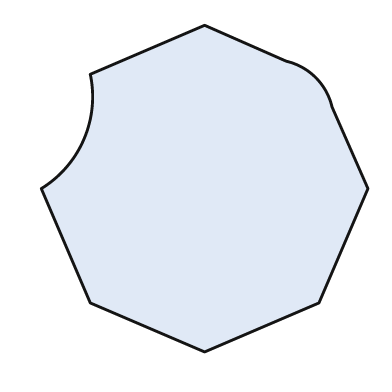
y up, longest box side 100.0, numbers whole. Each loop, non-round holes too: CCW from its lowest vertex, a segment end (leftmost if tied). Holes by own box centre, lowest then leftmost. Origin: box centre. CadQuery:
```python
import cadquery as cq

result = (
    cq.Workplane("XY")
    .moveTo(0.0, -50.0)
    .lineTo(35.0, -35.0)
    .lineTo(50.0, 0.0)
    .lineTo(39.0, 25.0)
    .threePointArc((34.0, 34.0), (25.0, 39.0))
    .lineTo(0.0, 50.0)
    .lineTo(-35.0, 35.0)
    .threePointArc((-37.0, 15.0), (-50.0, 0.0))
    .lineTo(-35.0, -35.0)
    .close()
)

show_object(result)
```